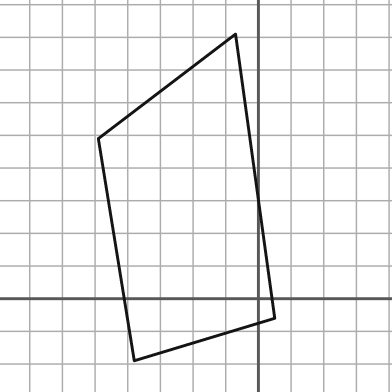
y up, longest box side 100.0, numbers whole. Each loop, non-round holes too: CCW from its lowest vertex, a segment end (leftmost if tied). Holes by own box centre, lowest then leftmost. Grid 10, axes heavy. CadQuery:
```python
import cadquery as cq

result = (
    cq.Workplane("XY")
    .moveTo(-38.0, -19.0)
    .lineTo(5.0, -6.0)
    .lineTo(-7.0, 81.0)
    .lineTo(-49.0, 49.0)
    .close()
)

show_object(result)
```